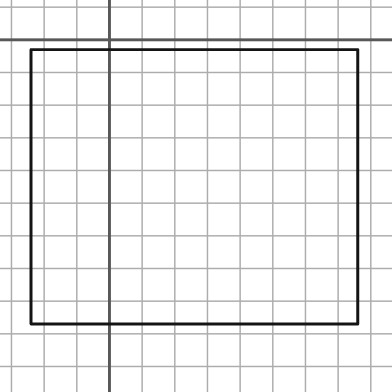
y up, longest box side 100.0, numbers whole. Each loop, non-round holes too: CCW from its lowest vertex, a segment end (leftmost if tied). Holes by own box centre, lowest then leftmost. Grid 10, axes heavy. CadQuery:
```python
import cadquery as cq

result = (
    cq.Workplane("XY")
    .moveTo(-24.0, -87.0)
    .lineTo(76.0, -87.0)
    .lineTo(76.0, -3.0)
    .lineTo(-24.0, -3.0)
    .close()
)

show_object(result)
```